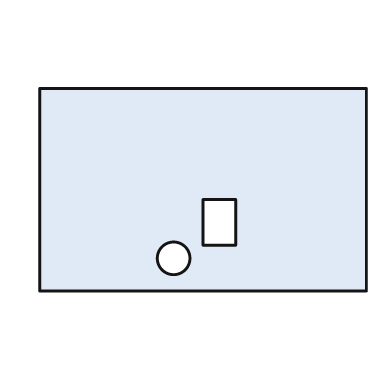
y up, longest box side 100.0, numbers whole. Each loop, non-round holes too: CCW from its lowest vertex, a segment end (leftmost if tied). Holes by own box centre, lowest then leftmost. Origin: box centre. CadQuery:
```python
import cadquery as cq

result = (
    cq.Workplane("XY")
    .moveTo(-50.0, -31.0)
    .lineTo(50.0, -31.0)
    .lineTo(50.0, 31.0)
    .lineTo(-50.0, 31.0)
    .close()
    .moveTo(-9.0, -21.0)
    .circle(5.0)
    .moveTo(0.0, -17.0)
    .lineTo(10.0, -17.0)
    .lineTo(10.0, -3.0)
    .lineTo(0.0, -3.0)
    .close()
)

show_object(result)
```